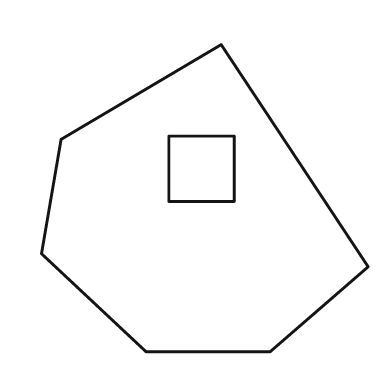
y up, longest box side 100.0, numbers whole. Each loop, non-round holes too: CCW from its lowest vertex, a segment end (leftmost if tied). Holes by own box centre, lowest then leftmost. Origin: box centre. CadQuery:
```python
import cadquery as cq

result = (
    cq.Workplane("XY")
    .moveTo(-18.0, -47.0)
    .lineTo(20.0, -47.0)
    .lineTo(50.0, -21.0)
    .lineTo(5.0, 47.0)
    .lineTo(-44.0, 18.0)
    .lineTo(-50.0, -17.0)
    .close()
    .moveTo(-11.0, -1.0)
    .lineTo(9.0, -1.0)
    .lineTo(9.0, 19.0)
    .lineTo(-11.0, 19.0)
    .close()
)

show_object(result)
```